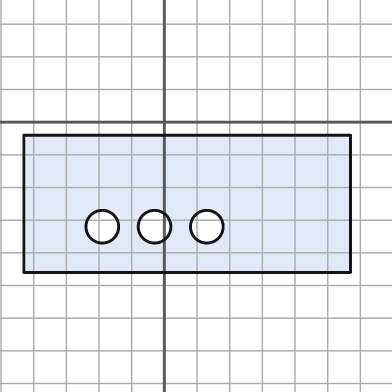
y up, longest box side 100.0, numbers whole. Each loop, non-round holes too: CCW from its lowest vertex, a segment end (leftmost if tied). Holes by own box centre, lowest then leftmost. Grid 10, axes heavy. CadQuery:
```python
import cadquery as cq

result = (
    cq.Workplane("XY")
    .moveTo(-43.0, -46.0)
    .lineTo(57.0, -46.0)
    .lineTo(57.0, -4.0)
    .lineTo(-43.0, -4.0)
    .close()
    .moveTo(-19.0, -32.0)
    .circle(5.0)
    .moveTo(-3.0, -32.0)
    .circle(5.0)
    .moveTo(13.0, -32.0)
    .circle(5.0)
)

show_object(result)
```